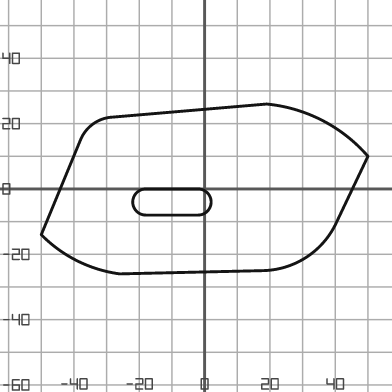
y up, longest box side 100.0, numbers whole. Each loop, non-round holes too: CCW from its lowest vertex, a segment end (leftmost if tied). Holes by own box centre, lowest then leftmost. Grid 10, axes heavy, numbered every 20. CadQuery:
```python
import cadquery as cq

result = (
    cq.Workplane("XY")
    .moveTo(-26.0, -26.0)
    .lineTo(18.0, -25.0)
    .threePointArc((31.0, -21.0), (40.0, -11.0))
    .lineTo(50.0, 10.0)
    .threePointArc((36.0, 21.0), (19.0, 26.0))
    .lineTo(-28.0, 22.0)
    .threePointArc((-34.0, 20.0), (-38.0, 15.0))
    .lineTo(-50.0, -14.0)
    .threePointArc((-39.0, -22.0), (-26.0, -26.0))
    .close()
    .moveTo(-18.0, -8.0)
    .lineTo(-2.0, -8.0)
    .threePointArc((2.0, -4.0), (-2.0, 0.0))
    .lineTo(-18.0, 0.0)
    .threePointArc((-22.0, -4.0), (-18.0, -8.0))
    .close()
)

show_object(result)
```